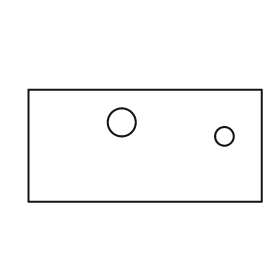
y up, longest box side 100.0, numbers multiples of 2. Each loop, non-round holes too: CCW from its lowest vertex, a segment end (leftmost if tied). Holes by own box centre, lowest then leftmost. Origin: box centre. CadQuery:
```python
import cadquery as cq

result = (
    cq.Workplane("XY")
    .moveTo(-50.0, -24.0)
    .lineTo(50.0, -24.0)
    .lineTo(50.0, 24.0)
    .lineTo(-50.0, 24.0)
    .close()
    .moveTo(34.0, 4.0)
    .circle(4.0)
    .moveTo(-10.0, 10.0)
    .circle(6.0)
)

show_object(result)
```